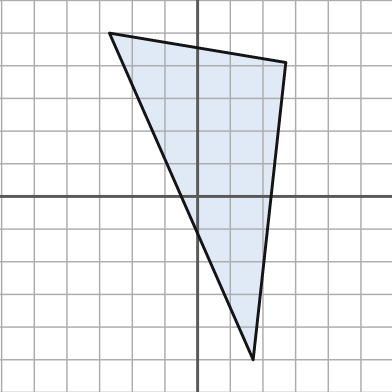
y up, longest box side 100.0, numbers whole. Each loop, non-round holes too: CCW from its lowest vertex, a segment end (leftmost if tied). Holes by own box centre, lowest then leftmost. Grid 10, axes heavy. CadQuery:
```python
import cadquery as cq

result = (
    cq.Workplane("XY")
    .moveTo(17.0, -50.0)
    .lineTo(27.0, 41.0)
    .lineTo(-27.0, 50.0)
    .close()
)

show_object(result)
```